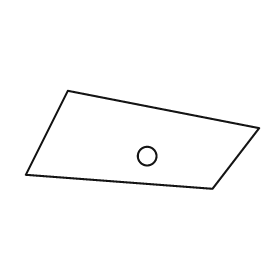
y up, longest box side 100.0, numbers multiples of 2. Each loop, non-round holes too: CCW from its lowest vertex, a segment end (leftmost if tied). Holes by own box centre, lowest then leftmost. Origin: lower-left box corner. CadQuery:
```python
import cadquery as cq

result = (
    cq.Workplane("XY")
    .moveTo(80.0, 0.0)
    .lineTo(100.0, 26.0)
    .lineTo(18.0, 42.0)
    .lineTo(0.0, 6.0)
    .close()
    .moveTo(52.0, 14.0)
    .circle(4.0)
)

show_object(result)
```